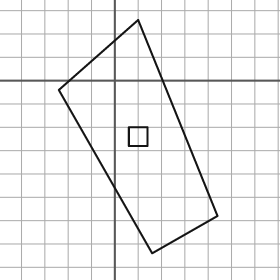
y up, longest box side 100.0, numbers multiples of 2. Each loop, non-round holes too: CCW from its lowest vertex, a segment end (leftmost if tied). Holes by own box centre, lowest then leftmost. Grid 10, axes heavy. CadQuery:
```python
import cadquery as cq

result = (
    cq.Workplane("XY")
    .moveTo(16.0, -74.0)
    .lineTo(44.0, -58.0)
    .lineTo(10.0, 26.0)
    .lineTo(-24.0, -4.0)
    .close()
    .moveTo(6.0, -28.0)
    .lineTo(14.0, -28.0)
    .lineTo(14.0, -20.0)
    .lineTo(6.0, -20.0)
    .close()
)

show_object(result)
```